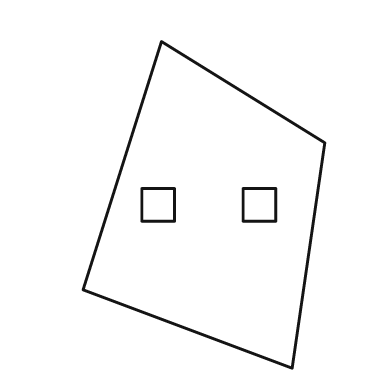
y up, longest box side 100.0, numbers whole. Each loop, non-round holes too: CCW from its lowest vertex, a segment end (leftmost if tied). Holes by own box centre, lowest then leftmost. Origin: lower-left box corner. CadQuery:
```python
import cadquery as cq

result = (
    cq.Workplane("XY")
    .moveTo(64.0, 0.0)
    .lineTo(74.0, 69.0)
    .lineTo(24.0, 100.0)
    .lineTo(0.0, 24.0)
    .close()
    .moveTo(18.0, 45.0)
    .lineTo(28.0, 45.0)
    .lineTo(28.0, 55.0)
    .lineTo(18.0, 55.0)
    .close()
    .moveTo(49.0, 45.0)
    .lineTo(59.0, 45.0)
    .lineTo(59.0, 55.0)
    .lineTo(49.0, 55.0)
    .close()
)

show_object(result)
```